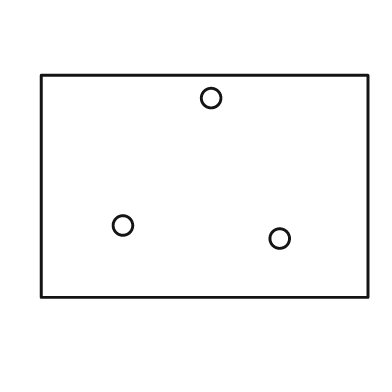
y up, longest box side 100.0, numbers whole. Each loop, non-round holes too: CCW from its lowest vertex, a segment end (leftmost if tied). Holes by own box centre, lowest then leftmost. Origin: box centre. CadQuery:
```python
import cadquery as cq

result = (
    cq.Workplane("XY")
    .moveTo(-50.0, -34.0)
    .lineTo(50.0, -34.0)
    .lineTo(50.0, 34.0)
    .lineTo(-50.0, 34.0)
    .close()
    .moveTo(23.0, -16.0)
    .circle(3.0)
    .moveTo(-25.0, -12.0)
    .circle(3.0)
    .moveTo(2.0, 27.0)
    .circle(3.0)
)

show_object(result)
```